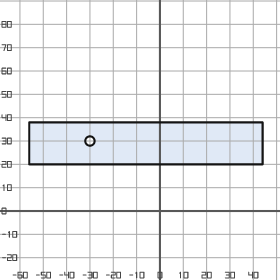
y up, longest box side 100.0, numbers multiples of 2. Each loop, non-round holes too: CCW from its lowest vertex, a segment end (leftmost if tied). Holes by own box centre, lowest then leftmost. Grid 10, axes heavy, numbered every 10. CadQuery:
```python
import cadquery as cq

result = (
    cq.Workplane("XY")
    .moveTo(-56.0, 20.0)
    .lineTo(44.0, 20.0)
    .lineTo(44.0, 38.0)
    .lineTo(-56.0, 38.0)
    .close()
    .moveTo(-30.0, 30.0)
    .circle(2.0)
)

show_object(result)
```